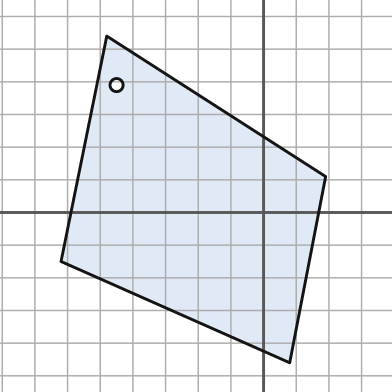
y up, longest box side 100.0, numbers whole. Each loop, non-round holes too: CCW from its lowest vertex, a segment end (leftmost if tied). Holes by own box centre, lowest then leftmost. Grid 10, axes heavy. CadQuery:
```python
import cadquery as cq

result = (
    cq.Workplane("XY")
    .moveTo(8.0, -46.0)
    .lineTo(19.0, 11.0)
    .lineTo(-48.0, 54.0)
    .lineTo(-62.0, -15.0)
    .close()
    .moveTo(-45.0, 39.0)
    .circle(2.0)
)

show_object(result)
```